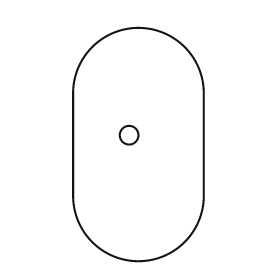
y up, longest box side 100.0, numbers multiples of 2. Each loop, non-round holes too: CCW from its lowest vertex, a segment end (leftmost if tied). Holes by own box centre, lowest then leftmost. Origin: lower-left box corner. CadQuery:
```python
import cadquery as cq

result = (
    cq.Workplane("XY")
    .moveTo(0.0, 28.0)
    .threePointArc((28.0, 0.0), (56.0, 28.0))
    .lineTo(56.0, 72.0)
    .threePointArc((28.0, 100.0), (0.0, 72.0))
    .close()
    .moveTo(24.0, 54.0)
    .circle(4.0)
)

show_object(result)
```